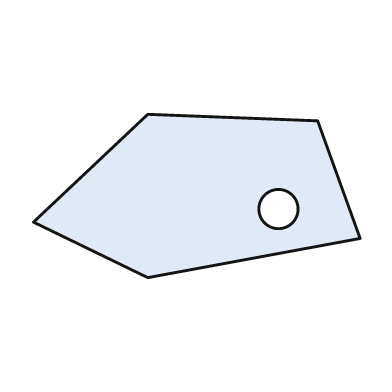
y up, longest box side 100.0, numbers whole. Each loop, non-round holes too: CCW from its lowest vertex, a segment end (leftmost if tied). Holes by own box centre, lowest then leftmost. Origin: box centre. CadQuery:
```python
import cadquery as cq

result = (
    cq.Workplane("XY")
    .moveTo(-15.0, -25.0)
    .lineTo(50.0, -13.0)
    .lineTo(37.0, 23.0)
    .lineTo(-15.0, 25.0)
    .lineTo(-50.0, -8.0)
    .close()
    .moveTo(25.0, -4.0)
    .circle(6.0)
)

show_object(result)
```